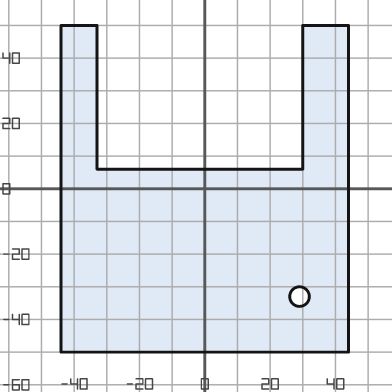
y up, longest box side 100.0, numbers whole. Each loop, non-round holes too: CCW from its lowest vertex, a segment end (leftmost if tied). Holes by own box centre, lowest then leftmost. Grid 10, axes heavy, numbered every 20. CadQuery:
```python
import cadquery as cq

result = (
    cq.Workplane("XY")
    .moveTo(-44.0, -50.0)
    .lineTo(44.0, -50.0)
    .lineTo(44.0, 50.0)
    .lineTo(30.0, 50.0)
    .lineTo(30.0, 6.0)
    .lineTo(-33.0, 6.0)
    .lineTo(-33.0, 50.0)
    .lineTo(-44.0, 50.0)
    .close()
    .moveTo(29.0, -33.0)
    .circle(3.0)
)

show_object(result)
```